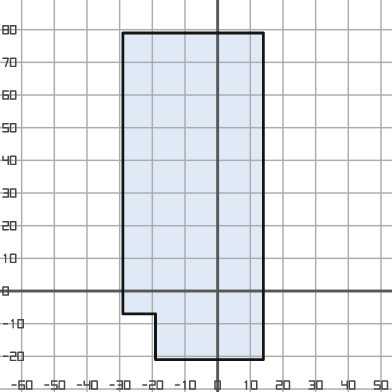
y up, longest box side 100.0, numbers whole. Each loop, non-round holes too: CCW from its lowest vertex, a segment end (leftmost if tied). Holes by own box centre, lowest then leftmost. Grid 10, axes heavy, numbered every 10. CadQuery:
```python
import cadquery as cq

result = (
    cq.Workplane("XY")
    .moveTo(-19.0, -21.0)
    .lineTo(14.0, -21.0)
    .lineTo(14.0, 79.0)
    .lineTo(-29.0, 79.0)
    .lineTo(-29.0, -7.0)
    .lineTo(-19.0, -7.0)
    .close()
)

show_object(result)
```